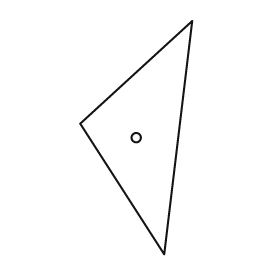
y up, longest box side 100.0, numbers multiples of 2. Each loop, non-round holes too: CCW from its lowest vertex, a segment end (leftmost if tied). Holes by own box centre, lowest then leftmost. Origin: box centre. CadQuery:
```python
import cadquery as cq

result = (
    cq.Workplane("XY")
    .moveTo(12.0, -50.0)
    .lineTo(24.0, 50.0)
    .lineTo(-24.0, 6.0)
    .close()
    .moveTo(0.0, 0.0)
    .circle(2.0)
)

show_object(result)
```